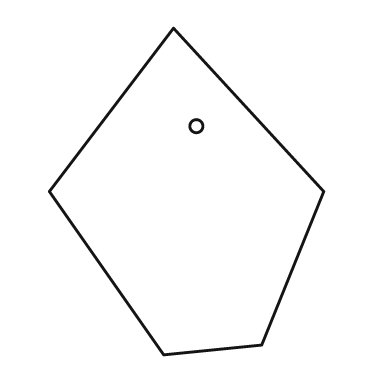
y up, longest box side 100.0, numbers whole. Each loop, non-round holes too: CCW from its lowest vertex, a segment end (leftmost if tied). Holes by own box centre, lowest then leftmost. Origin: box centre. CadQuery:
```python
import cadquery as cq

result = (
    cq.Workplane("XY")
    .moveTo(-7.0, -50.0)
    .lineTo(23.0, -47.0)
    .lineTo(42.0, 0.0)
    .lineTo(-4.0, 50.0)
    .lineTo(-42.0, 0.0)
    .close()
    .moveTo(3.0, 20.0)
    .circle(2.0)
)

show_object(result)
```